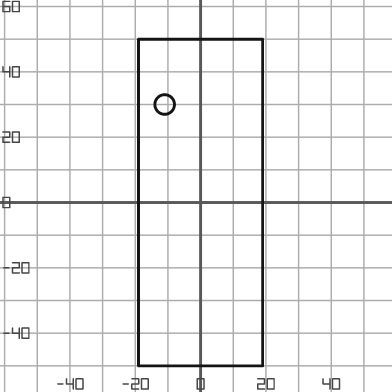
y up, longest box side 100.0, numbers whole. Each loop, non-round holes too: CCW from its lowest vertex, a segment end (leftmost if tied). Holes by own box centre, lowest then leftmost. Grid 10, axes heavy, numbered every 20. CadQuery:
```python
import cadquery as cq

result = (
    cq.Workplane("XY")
    .moveTo(-19.0, -50.0)
    .lineTo(19.0, -50.0)
    .lineTo(19.0, 50.0)
    .lineTo(-19.0, 50.0)
    .close()
    .moveTo(-11.0, 30.0)
    .circle(3.0)
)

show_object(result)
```